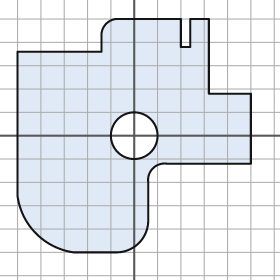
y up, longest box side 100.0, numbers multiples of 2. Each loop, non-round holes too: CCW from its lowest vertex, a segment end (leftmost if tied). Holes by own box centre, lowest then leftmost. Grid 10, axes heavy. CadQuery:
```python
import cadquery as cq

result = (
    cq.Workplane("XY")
    .moveTo(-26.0, -50.0)
    .lineTo(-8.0, -50.0)
    .threePointArc((2.0, -46.0), (6.0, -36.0))
    .lineTo(6.0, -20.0)
    .threePointArc((8.0, -14.0), (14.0, -12.0))
    .lineTo(50.0, -12.0)
    .lineTo(50.0, 18.0)
    .lineTo(32.0, 18.0)
    .lineTo(32.0, 50.0)
    .lineTo(24.0, 50.0)
    .lineTo(24.0, 38.0)
    .lineTo(20.0, 38.0)
    .lineTo(20.0, 50.0)
    .lineTo(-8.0, 50.0)
    .threePointArc((-12.0, 48.0), (-14.0, 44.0))
    .lineTo(-14.0, 36.0)
    .lineTo(-50.0, 36.0)
    .lineTo(-50.0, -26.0)
    .threePointArc((-42.0, -42.0), (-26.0, -50.0))
    .close()
    .moveTo(0.0, 0.0)
    .circle(10.0)
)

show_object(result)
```